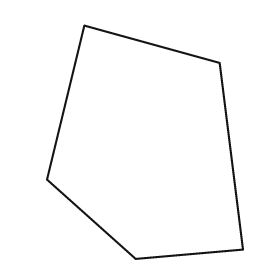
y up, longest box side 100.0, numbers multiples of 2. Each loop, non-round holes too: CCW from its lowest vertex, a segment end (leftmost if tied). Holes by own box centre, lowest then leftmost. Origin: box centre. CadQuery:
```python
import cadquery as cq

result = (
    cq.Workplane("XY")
    .moveTo(-4.0, -50.0)
    .lineTo(42.0, -46.0)
    .lineTo(32.0, 34.0)
    .lineTo(-26.0, 50.0)
    .lineTo(-42.0, -16.0)
    .close()
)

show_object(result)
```